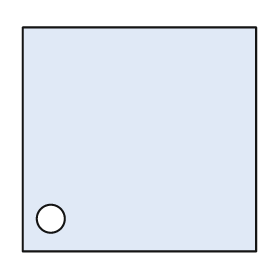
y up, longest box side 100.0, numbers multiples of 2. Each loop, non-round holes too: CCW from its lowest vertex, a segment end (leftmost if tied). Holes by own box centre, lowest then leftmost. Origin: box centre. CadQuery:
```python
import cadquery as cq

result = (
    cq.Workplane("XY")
    .moveTo(-50.0, -48.0)
    .lineTo(50.0, -48.0)
    .lineTo(50.0, 48.0)
    .lineTo(-50.0, 48.0)
    .close()
    .moveTo(-38.0, -34.0)
    .circle(6.0)
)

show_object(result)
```